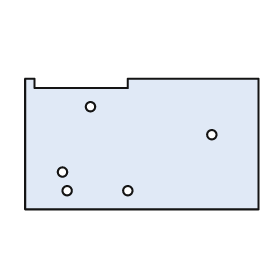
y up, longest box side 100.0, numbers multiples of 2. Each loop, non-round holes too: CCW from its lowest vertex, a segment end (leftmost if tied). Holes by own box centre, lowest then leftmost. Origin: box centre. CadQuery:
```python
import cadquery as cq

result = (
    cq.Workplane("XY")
    .moveTo(-50.0, -28.0)
    .lineTo(50.0, -28.0)
    .lineTo(50.0, 28.0)
    .lineTo(-6.0, 28.0)
    .lineTo(-6.0, 24.0)
    .lineTo(-46.0, 24.0)
    .lineTo(-46.0, 28.0)
    .lineTo(-50.0, 28.0)
    .close()
    .moveTo(-32.0, -20.0)
    .circle(2.0)
    .moveTo(-6.0, -20.0)
    .circle(2.0)
    .moveTo(-34.0, -12.0)
    .circle(2.0)
    .moveTo(30.0, 4.0)
    .circle(2.0)
    .moveTo(-22.0, 16.0)
    .circle(2.0)
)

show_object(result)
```